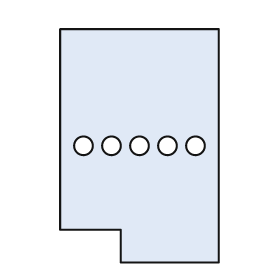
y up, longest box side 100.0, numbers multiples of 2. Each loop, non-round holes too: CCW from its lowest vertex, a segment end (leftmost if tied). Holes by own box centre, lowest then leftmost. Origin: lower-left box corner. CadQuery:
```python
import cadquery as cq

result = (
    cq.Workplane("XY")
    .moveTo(26.0, 0.0)
    .lineTo(68.0, 0.0)
    .lineTo(68.0, 100.0)
    .lineTo(0.0, 100.0)
    .lineTo(0.0, 14.0)
    .lineTo(26.0, 14.0)
    .close()
    .moveTo(10.0, 50.0)
    .circle(4.0)
    .moveTo(22.0, 50.0)
    .circle(4.0)
    .moveTo(34.0, 50.0)
    .circle(4.0)
    .moveTo(46.0, 50.0)
    .circle(4.0)
    .moveTo(58.0, 50.0)
    .circle(4.0)
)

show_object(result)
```